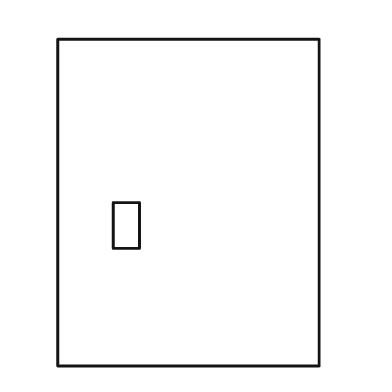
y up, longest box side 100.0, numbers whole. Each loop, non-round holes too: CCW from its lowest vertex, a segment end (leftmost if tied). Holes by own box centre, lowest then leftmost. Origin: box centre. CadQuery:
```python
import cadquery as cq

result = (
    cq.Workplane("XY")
    .moveTo(-40.0, -50.0)
    .lineTo(40.0, -50.0)
    .lineTo(40.0, 50.0)
    .lineTo(-40.0, 50.0)
    .close()
    .moveTo(-23.0, -14.0)
    .lineTo(-15.0, -14.0)
    .lineTo(-15.0, 0.0)
    .lineTo(-23.0, 0.0)
    .close()
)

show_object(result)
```